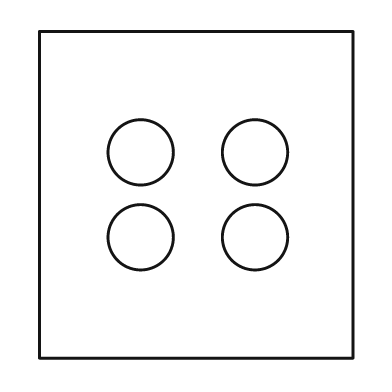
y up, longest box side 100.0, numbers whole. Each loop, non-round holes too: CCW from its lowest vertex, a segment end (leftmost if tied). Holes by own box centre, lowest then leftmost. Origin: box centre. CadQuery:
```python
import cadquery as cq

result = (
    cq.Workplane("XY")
    .moveTo(-48.0, -50.0)
    .lineTo(48.0, -50.0)
    .lineTo(48.0, 50.0)
    .lineTo(-48.0, 50.0)
    .close()
    .moveTo(-17.0, -13.0)
    .circle(10.0)
    .moveTo(18.0, -13.0)
    .circle(10.0)
    .moveTo(-17.0, 13.0)
    .circle(10.0)
    .moveTo(18.0, 13.0)
    .circle(10.0)
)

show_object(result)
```